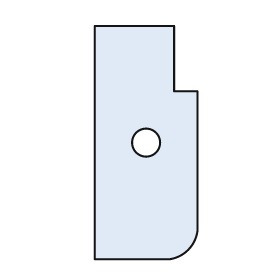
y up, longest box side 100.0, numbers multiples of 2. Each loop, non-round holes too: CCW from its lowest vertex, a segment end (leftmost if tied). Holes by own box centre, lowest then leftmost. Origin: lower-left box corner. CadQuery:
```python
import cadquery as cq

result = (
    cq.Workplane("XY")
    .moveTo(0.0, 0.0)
    .lineTo(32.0, 0.0)
    .threePointArc((40.0, 4.0), (44.0, 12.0))
    .lineTo(44.0, 72.0)
    .lineTo(34.0, 72.0)
    .lineTo(34.0, 100.0)
    .lineTo(0.0, 100.0)
    .close()
    .moveTo(22.0, 50.0)
    .circle(6.0)
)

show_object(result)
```